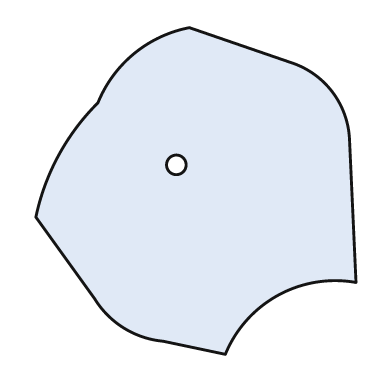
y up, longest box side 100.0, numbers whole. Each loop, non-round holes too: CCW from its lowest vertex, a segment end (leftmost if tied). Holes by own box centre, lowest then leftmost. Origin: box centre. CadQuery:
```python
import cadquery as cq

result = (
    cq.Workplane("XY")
    .moveTo(9.0, -50.0)
    .threePointArc((25.0, -32.0), (49.0, -28.0))
    .lineTo(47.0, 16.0)
    .threePointArc((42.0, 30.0), (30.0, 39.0))
    .lineTo(-2.0, 50.0)
    .threePointArc((-19.0, 42.0), (-30.0, 27.0))
    .threePointArc((-42.0, 11.0), (-49.0, -8.0))
    .lineTo(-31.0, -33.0)
    .threePointArc((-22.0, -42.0), (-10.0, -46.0))
    .close()
    .moveTo(-6.0, 8.0)
    .circle(3.0)
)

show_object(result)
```